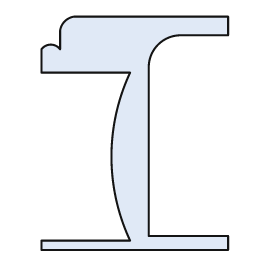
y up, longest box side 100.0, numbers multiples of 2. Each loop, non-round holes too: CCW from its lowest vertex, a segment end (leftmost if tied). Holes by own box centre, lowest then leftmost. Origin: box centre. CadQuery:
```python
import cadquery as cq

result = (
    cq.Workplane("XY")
    .moveTo(-40.0, -50.0)
    .lineTo(40.0, -50.0)
    .lineTo(40.0, -44.0)
    .lineTo(6.0, -44.0)
    .lineTo(6.0, 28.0)
    .threePointArc((10.0, 38.0), (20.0, 42.0))
    .lineTo(40.0, 42.0)
    .lineTo(40.0, 50.0)
    .lineTo(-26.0, 50.0)
    .threePointArc((-30.0, 48.0), (-32.0, 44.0))
    .lineTo(-32.0, 36.0)
    .threePointArc((-36.0, 38.0), (-40.0, 36.0))
    .lineTo(-40.0, 26.0)
    .lineTo(-2.0, 26.0)
    .threePointArc((-10.0, -10.0), (-2.0, -46.0))
    .lineTo(-40.0, -46.0)
    .close()
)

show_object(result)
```